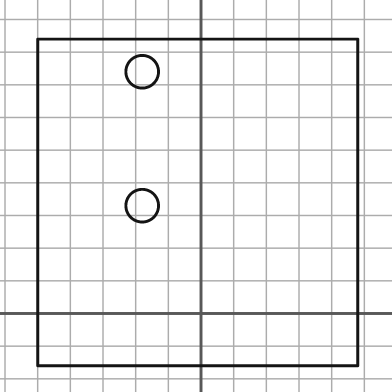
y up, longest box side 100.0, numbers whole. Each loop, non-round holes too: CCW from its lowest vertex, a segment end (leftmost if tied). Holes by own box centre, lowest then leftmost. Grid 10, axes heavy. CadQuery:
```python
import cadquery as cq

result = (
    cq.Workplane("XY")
    .moveTo(-50.0, -16.0)
    .lineTo(48.0, -16.0)
    .lineTo(48.0, 84.0)
    .lineTo(-50.0, 84.0)
    .close()
    .moveTo(-18.0, 33.0)
    .circle(5.0)
    .moveTo(-18.0, 74.0)
    .circle(5.0)
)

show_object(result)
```